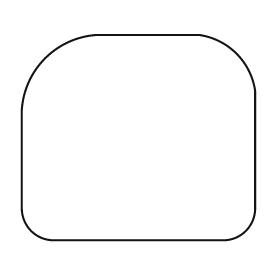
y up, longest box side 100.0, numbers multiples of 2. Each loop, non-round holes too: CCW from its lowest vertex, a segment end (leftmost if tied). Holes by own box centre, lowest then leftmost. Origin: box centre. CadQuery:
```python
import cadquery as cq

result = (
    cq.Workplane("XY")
    .moveTo(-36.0, -44.0)
    .lineTo(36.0, -44.0)
    .threePointArc((46.0, -40.0), (50.0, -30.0))
    .lineTo(50.0, 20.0)
    .threePointArc((42.0, 36.0), (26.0, 44.0))
    .lineTo(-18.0, 44.0)
    .threePointArc((-40.0, 34.0), (-50.0, 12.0))
    .lineTo(-50.0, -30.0)
    .threePointArc((-46.0, -40.0), (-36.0, -44.0))
    .close()
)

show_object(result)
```